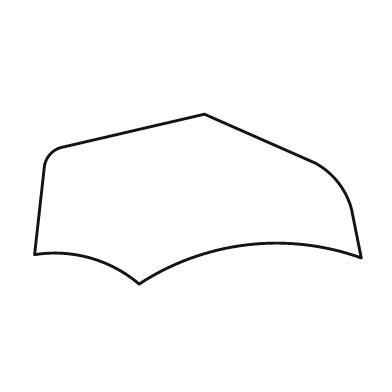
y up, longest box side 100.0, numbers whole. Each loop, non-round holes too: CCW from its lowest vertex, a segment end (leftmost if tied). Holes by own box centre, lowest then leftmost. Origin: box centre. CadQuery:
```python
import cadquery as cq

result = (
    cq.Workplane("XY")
    .moveTo(-18.0, -26.0)
    .threePointArc((15.0, -14.0), (50.0, -18.0))
    .lineTo(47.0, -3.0)
    .threePointArc((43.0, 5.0), (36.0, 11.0))
    .lineTo(2.0, 26.0)
    .lineTo(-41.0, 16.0)
    .threePointArc((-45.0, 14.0), (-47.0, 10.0))
    .lineTo(-50.0, -17.0)
    .threePointArc((-33.0, -18.0), (-18.0, -26.0))
    .close()
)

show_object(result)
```